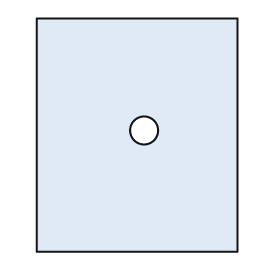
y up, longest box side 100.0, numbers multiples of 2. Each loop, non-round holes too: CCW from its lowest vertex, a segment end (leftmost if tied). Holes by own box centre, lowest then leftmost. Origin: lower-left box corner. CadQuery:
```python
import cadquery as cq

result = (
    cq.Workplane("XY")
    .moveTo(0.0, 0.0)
    .lineTo(86.0, 0.0)
    .lineTo(86.0, 100.0)
    .lineTo(0.0, 100.0)
    .close()
    .moveTo(46.0, 52.0)
    .circle(6.0)
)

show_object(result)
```